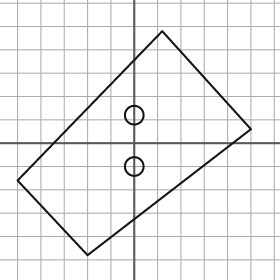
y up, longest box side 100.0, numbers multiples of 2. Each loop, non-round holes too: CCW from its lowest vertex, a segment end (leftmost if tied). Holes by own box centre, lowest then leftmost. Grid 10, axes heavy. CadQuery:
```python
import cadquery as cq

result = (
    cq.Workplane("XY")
    .moveTo(-20.0, -48.0)
    .lineTo(50.0, 6.0)
    .lineTo(12.0, 48.0)
    .lineTo(-50.0, -16.0)
    .close()
    .moveTo(0.0, -10.0)
    .circle(4.0)
    .moveTo(0.0, 12.0)
    .circle(4.0)
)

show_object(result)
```